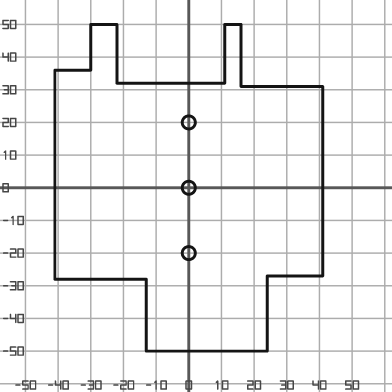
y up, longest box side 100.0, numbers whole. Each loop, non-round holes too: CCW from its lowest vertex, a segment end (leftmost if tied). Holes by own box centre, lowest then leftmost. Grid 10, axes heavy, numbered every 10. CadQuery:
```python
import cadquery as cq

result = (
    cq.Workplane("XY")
    .moveTo(-13.0, -50.0)
    .lineTo(24.0, -50.0)
    .lineTo(24.0, -27.0)
    .lineTo(41.0, -27.0)
    .lineTo(41.0, 31.0)
    .lineTo(16.0, 31.0)
    .lineTo(16.0, 50.0)
    .lineTo(11.0, 50.0)
    .lineTo(11.0, 32.0)
    .lineTo(-22.0, 32.0)
    .lineTo(-22.0, 50.0)
    .lineTo(-30.0, 50.0)
    .lineTo(-30.0, 36.0)
    .lineTo(-41.0, 36.0)
    .lineTo(-41.0, -28.0)
    .lineTo(-13.0, -28.0)
    .close()
    .moveTo(0.0, -20.0)
    .circle(2.0)
    .moveTo(0.0, 0.0)
    .circle(2.0)
    .moveTo(0.0, 20.0)
    .circle(2.0)
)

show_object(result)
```